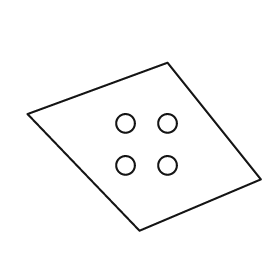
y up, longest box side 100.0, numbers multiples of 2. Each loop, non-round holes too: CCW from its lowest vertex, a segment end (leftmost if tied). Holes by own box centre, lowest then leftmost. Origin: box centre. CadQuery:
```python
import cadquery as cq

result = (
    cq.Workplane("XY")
    .moveTo(-2.0, -36.0)
    .lineTo(50.0, -14.0)
    .lineTo(10.0, 36.0)
    .lineTo(-50.0, 14.0)
    .close()
    .moveTo(-8.0, -8.0)
    .circle(4.0)
    .moveTo(10.0, -8.0)
    .circle(4.0)
    .moveTo(-8.0, 10.0)
    .circle(4.0)
    .moveTo(10.0, 10.0)
    .circle(4.0)
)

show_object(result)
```